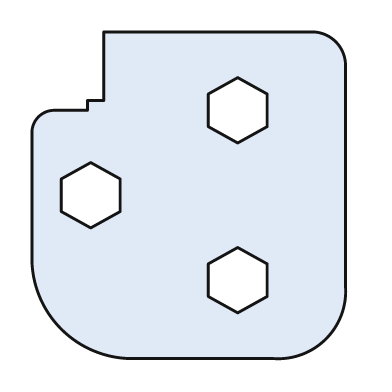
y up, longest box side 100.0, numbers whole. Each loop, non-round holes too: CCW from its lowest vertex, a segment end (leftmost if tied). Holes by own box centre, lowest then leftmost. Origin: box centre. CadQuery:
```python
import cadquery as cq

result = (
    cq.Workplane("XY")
    .moveTo(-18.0, -50.0)
    .lineTo(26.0, -50.0)
    .threePointArc((42.0, -44.0), (48.0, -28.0))
    .lineTo(48.0, 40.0)
    .threePointArc((45.0, 47.0), (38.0, 50.0))
    .lineTo(-26.0, 50.0)
    .lineTo(-26.0, 29.0)
    .lineTo(-31.0, 29.0)
    .lineTo(-31.0, 26.0)
    .lineTo(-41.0, 26.0)
    .threePointArc((-46.0, 24.0), (-48.0, 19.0))
    .lineTo(-48.0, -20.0)
    .threePointArc((-39.0, -41.0), (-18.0, -50.0))
    .close()
    .moveTo(15.0, -36.0)
    .lineTo(24.0, -31.0)
    .lineTo(24.0, -21.0)
    .lineTo(15.0, -16.0)
    .lineTo(6.0, -21.0)
    .lineTo(6.0, -31.0)
    .close()
    .moveTo(-30.0, -10.0)
    .lineTo(-21.0, -5.0)
    .lineTo(-21.0, 5.0)
    .lineTo(-30.0, 10.0)
    .lineTo(-39.0, 5.0)
    .lineTo(-39.0, -5.0)
    .close()
    .moveTo(15.0, 16.0)
    .lineTo(24.0, 21.0)
    .lineTo(24.0, 31.0)
    .lineTo(15.0, 36.0)
    .lineTo(6.0, 31.0)
    .lineTo(6.0, 21.0)
    .close()
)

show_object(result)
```